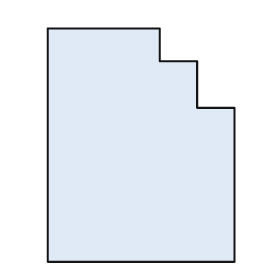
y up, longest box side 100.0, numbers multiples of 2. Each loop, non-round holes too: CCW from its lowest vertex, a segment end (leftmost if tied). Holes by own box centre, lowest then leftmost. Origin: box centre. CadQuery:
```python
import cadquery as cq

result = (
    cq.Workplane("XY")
    .moveTo(-40.0, -50.0)
    .lineTo(40.0, -50.0)
    .lineTo(40.0, 16.0)
    .lineTo(24.0, 16.0)
    .lineTo(24.0, 36.0)
    .lineTo(8.0, 36.0)
    .lineTo(8.0, 50.0)
    .lineTo(-40.0, 50.0)
    .close()
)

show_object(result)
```